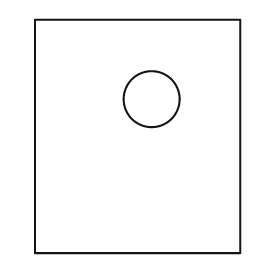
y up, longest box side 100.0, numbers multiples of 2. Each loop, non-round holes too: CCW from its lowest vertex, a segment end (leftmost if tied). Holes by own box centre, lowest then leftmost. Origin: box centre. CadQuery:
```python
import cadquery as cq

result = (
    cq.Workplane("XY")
    .moveTo(-44.0, -50.0)
    .lineTo(44.0, -50.0)
    .lineTo(44.0, 50.0)
    .lineTo(-44.0, 50.0)
    .close()
    .moveTo(6.0, 16.0)
    .circle(12.0)
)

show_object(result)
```